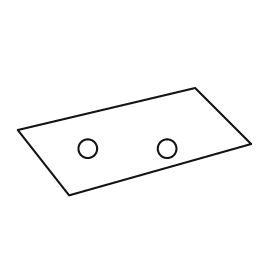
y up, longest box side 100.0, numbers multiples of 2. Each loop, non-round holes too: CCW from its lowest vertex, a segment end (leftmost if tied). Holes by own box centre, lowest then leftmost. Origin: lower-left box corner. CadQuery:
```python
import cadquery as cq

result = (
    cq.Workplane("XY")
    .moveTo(22.0, 0.0)
    .lineTo(100.0, 22.0)
    .lineTo(76.0, 46.0)
    .lineTo(0.0, 28.0)
    .close()
    .moveTo(30.0, 20.0)
    .circle(4.0)
    .moveTo(64.0, 20.0)
    .circle(4.0)
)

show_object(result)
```